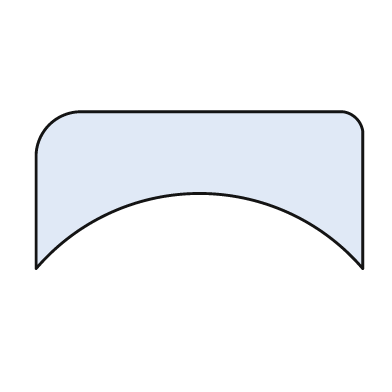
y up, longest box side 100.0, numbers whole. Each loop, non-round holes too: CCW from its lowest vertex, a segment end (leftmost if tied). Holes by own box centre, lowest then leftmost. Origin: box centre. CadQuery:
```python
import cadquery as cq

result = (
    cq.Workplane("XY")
    .moveTo(-50.0, -24.0)
    .threePointArc((0.0, -1.0), (50.0, -24.0))
    .lineTo(50.0, 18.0)
    .threePointArc((48.0, 22.0), (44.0, 24.0))
    .lineTo(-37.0, 24.0)
    .threePointArc((-46.0, 20.0), (-50.0, 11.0))
    .close()
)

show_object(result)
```